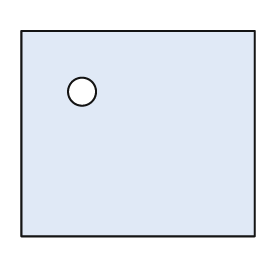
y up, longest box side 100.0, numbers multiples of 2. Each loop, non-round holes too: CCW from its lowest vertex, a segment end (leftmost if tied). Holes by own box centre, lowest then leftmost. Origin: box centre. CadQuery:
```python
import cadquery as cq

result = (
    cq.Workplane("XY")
    .moveTo(-50.0, -44.0)
    .lineTo(50.0, -44.0)
    .lineTo(50.0, 44.0)
    .lineTo(-50.0, 44.0)
    .close()
    .moveTo(-24.0, 18.0)
    .circle(6.0)
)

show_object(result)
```